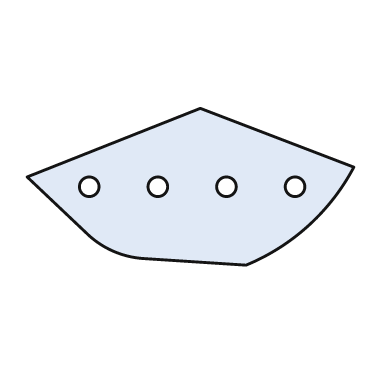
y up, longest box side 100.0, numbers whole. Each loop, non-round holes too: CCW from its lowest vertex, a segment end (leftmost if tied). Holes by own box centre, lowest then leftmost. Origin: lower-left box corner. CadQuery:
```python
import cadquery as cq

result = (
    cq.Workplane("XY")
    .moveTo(67.0, 0.0)
    .threePointArc((86.0, 12.0), (100.0, 30.0))
    .lineTo(53.0, 48.0)
    .lineTo(0.0, 27.0)
    .lineTo(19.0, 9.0)
    .threePointArc((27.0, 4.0), (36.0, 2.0))
    .close()
    .moveTo(19.0, 24.0)
    .circle(3.0)
    .moveTo(40.0, 24.0)
    .circle(3.0)
    .moveTo(61.0, 24.0)
    .circle(3.0)
    .moveTo(82.0, 24.0)
    .circle(3.0)
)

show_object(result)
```